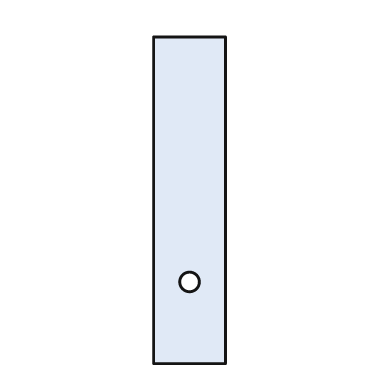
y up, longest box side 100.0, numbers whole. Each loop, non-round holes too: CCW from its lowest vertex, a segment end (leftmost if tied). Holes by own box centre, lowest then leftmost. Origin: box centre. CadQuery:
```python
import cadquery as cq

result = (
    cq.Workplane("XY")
    .moveTo(-11.0, -50.0)
    .lineTo(11.0, -50.0)
    .lineTo(11.0, 50.0)
    .lineTo(-11.0, 50.0)
    .close()
    .moveTo(0.0, -25.0)
    .circle(3.0)
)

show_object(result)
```